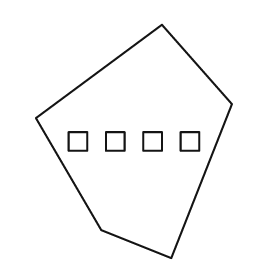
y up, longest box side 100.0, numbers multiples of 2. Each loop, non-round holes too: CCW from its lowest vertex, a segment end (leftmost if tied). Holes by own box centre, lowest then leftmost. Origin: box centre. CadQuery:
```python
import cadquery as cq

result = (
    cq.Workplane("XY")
    .moveTo(16.0, -50.0)
    .lineTo(42.0, 16.0)
    .lineTo(12.0, 50.0)
    .lineTo(-42.0, 10.0)
    .lineTo(-14.0, -38.0)
    .close()
    .moveTo(-28.0, -4.0)
    .lineTo(-20.0, -4.0)
    .lineTo(-20.0, 4.0)
    .lineTo(-28.0, 4.0)
    .close()
    .moveTo(-12.0, -4.0)
    .lineTo(-4.0, -4.0)
    .lineTo(-4.0, 4.0)
    .lineTo(-12.0, 4.0)
    .close()
    .moveTo(4.0, -4.0)
    .lineTo(12.0, -4.0)
    .lineTo(12.0, 4.0)
    .lineTo(4.0, 4.0)
    .close()
    .moveTo(20.0, -4.0)
    .lineTo(28.0, -4.0)
    .lineTo(28.0, 4.0)
    .lineTo(20.0, 4.0)
    .close()
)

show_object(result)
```